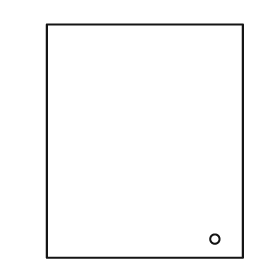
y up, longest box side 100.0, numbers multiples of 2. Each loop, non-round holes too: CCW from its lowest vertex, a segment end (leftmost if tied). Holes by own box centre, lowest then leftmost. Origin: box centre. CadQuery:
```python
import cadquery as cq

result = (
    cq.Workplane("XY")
    .moveTo(-42.0, -50.0)
    .lineTo(42.0, -50.0)
    .lineTo(42.0, 50.0)
    .lineTo(-42.0, 50.0)
    .close()
    .moveTo(30.0, -42.0)
    .circle(2.0)
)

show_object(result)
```